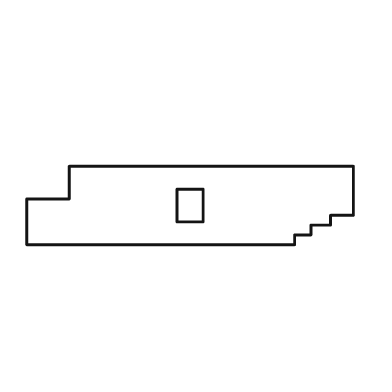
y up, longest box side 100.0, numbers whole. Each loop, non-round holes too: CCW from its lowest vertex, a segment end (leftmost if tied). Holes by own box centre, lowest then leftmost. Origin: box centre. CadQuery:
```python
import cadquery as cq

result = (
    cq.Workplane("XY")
    .moveTo(-50.0, -12.0)
    .lineTo(32.0, -12.0)
    .lineTo(32.0, -9.0)
    .lineTo(37.0, -9.0)
    .lineTo(37.0, -6.0)
    .lineTo(43.0, -6.0)
    .lineTo(43.0, -3.0)
    .lineTo(50.0, -3.0)
    .lineTo(50.0, 12.0)
    .lineTo(-37.0, 12.0)
    .lineTo(-37.0, 2.0)
    .lineTo(-50.0, 2.0)
    .close()
    .moveTo(-4.0, -5.0)
    .lineTo(4.0, -5.0)
    .lineTo(4.0, 5.0)
    .lineTo(-4.0, 5.0)
    .close()
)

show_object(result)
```